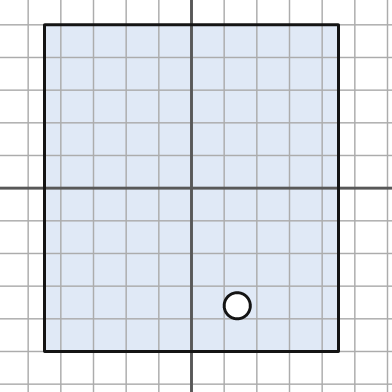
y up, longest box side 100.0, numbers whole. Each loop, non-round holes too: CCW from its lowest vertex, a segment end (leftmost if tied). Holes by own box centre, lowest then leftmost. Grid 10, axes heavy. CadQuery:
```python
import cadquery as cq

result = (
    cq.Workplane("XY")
    .moveTo(-45.0, -50.0)
    .lineTo(45.0, -50.0)
    .lineTo(45.0, 50.0)
    .lineTo(-45.0, 50.0)
    .close()
    .moveTo(14.0, -36.0)
    .circle(4.0)
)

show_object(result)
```